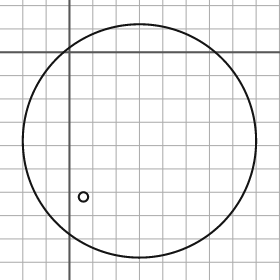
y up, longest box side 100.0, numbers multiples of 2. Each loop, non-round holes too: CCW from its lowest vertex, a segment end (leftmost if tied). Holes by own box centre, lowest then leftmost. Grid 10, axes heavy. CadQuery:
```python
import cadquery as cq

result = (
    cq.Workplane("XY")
    .moveTo(30.0, -38.0)
    .circle(50.0)
    .moveTo(6.0, -62.0)
    .circle(2.0)
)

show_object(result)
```